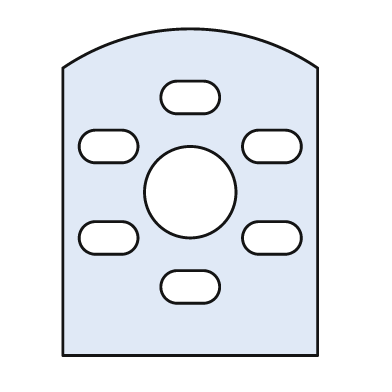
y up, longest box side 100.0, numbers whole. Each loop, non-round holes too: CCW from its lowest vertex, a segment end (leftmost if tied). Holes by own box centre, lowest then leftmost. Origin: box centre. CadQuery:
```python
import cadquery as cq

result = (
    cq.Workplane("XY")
    .moveTo(-39.0, -50.0)
    .lineTo(39.0, -50.0)
    .lineTo(39.0, 38.0)
    .threePointArc((0.0, 50.0), (-39.0, 38.0))
    .close()
    .moveTo(-4.0, -34.0)
    .lineTo(4.0, -34.0)
    .threePointArc((9.0, -29.0), (4.0, -24.0))
    .lineTo(-4.0, -24.0)
    .threePointArc((-9.0, -29.0), (-4.0, -34.0))
    .close()
    .moveTo(-29.0, -19.0)
    .lineTo(-21.0, -19.0)
    .threePointArc((-16.0, -14.0), (-21.0, -9.0))
    .lineTo(-29.0, -9.0)
    .threePointArc((-34.0, -14.0), (-29.0, -19.0))
    .close()
    .moveTo(21.0, -19.0)
    .lineTo(29.0, -19.0)
    .threePointArc((34.0, -14.0), (29.0, -9.0))
    .lineTo(21.0, -9.0)
    .threePointArc((16.0, -14.0), (21.0, -19.0))
    .close()
    .moveTo(0.0, 0.0)
    .circle(14.0)
    .moveTo(-29.0, 9.0)
    .lineTo(-21.0, 9.0)
    .threePointArc((-16.0, 14.0), (-21.0, 19.0))
    .lineTo(-29.0, 19.0)
    .threePointArc((-34.0, 14.0), (-29.0, 9.0))
    .close()
    .moveTo(21.0, 9.0)
    .lineTo(29.0, 9.0)
    .threePointArc((34.0, 14.0), (29.0, 19.0))
    .lineTo(21.0, 19.0)
    .threePointArc((16.0, 14.0), (21.0, 9.0))
    .close()
    .moveTo(-4.0, 24.0)
    .lineTo(4.0, 24.0)
    .threePointArc((9.0, 29.0), (4.0, 34.0))
    .lineTo(-4.0, 34.0)
    .threePointArc((-9.0, 29.0), (-4.0, 24.0))
    .close()
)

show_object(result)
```